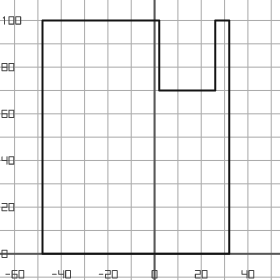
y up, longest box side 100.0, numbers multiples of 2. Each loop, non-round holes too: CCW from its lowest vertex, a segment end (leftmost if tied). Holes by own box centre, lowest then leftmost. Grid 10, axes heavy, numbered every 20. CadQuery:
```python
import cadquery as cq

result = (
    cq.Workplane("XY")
    .moveTo(-48.0, 0.0)
    .lineTo(32.0, 0.0)
    .lineTo(32.0, 100.0)
    .lineTo(26.0, 100.0)
    .lineTo(26.0, 70.0)
    .lineTo(2.0, 70.0)
    .lineTo(2.0, 100.0)
    .lineTo(-48.0, 100.0)
    .close()
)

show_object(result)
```